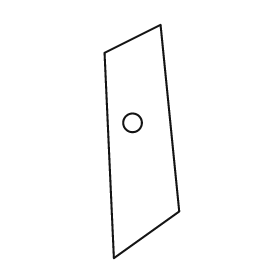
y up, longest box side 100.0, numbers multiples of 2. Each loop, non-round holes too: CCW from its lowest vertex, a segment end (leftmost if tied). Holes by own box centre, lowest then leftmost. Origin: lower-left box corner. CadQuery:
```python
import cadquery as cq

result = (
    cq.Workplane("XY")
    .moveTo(4.0, 0.0)
    .lineTo(32.0, 20.0)
    .lineTo(24.0, 100.0)
    .lineTo(0.0, 88.0)
    .close()
    .moveTo(12.0, 58.0)
    .circle(4.0)
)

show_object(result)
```